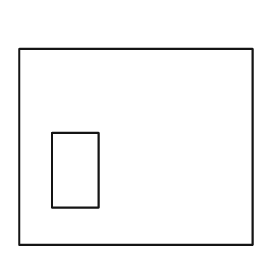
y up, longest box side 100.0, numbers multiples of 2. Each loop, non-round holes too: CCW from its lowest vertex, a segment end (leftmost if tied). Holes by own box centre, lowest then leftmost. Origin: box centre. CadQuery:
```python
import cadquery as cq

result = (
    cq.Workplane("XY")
    .moveTo(-50.0, -42.0)
    .lineTo(50.0, -42.0)
    .lineTo(50.0, 42.0)
    .lineTo(-50.0, 42.0)
    .close()
    .moveTo(-36.0, -26.0)
    .lineTo(-16.0, -26.0)
    .lineTo(-16.0, 6.0)
    .lineTo(-36.0, 6.0)
    .close()
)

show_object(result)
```